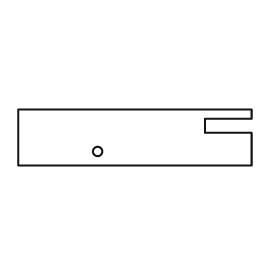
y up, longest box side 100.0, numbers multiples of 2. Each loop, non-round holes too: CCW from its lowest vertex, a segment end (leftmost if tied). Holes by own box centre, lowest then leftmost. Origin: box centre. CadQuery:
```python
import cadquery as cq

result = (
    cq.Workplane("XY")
    .moveTo(-50.0, -12.0)
    .lineTo(50.0, -12.0)
    .lineTo(50.0, 2.0)
    .lineTo(30.0, 2.0)
    .lineTo(30.0, 8.0)
    .lineTo(50.0, 8.0)
    .lineTo(50.0, 12.0)
    .lineTo(-50.0, 12.0)
    .close()
    .moveTo(-16.0, -6.0)
    .circle(2.0)
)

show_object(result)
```